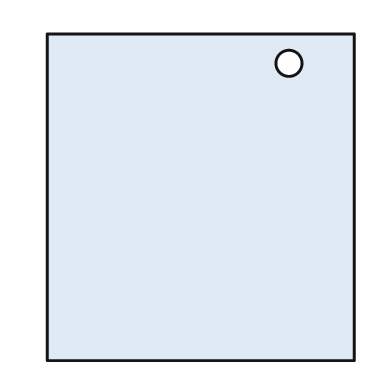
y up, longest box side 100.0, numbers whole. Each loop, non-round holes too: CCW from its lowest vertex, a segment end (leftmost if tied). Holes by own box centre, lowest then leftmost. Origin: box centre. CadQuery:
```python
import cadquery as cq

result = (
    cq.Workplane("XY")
    .moveTo(-47.0, -50.0)
    .lineTo(47.0, -50.0)
    .lineTo(47.0, 50.0)
    .lineTo(-47.0, 50.0)
    .close()
    .moveTo(27.0, 41.0)
    .circle(4.0)
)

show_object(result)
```